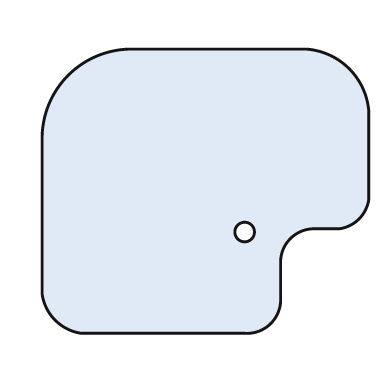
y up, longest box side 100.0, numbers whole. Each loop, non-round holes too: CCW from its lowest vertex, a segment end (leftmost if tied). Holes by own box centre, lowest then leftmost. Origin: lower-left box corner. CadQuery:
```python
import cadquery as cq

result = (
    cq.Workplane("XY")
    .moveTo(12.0, 0.0)
    .lineTo(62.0, 0.0)
    .threePointArc((70.0, 3.0), (73.0, 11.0))
    .lineTo(73.0, 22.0)
    .threePointArc((76.0, 29.0), (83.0, 32.0))
    .lineTo(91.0, 32.0)
    .threePointArc((97.0, 35.0), (100.0, 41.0))
    .lineTo(100.0, 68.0)
    .threePointArc((94.0, 81.0), (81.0, 87.0))
    .lineTo(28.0, 87.0)
    .threePointArc((8.0, 79.0), (0.0, 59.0))
    .lineTo(0.0, 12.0)
    .threePointArc((4.0, 4.0), (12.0, 0.0))
    .close()
    .moveTo(62.0, 31.0)
    .circle(3.0)
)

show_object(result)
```